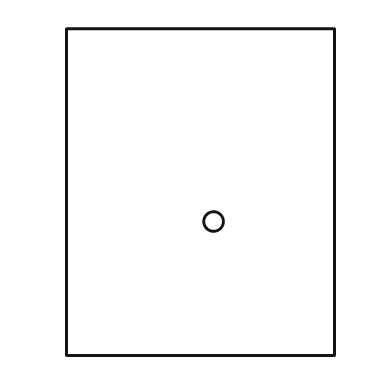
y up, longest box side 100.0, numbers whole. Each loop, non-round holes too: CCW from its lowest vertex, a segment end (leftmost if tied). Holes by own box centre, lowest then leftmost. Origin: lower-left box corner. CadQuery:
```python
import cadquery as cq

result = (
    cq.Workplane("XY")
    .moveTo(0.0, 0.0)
    .lineTo(82.0, 0.0)
    .lineTo(82.0, 100.0)
    .lineTo(0.0, 100.0)
    .close()
    .moveTo(45.0, 41.0)
    .circle(3.0)
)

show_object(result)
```